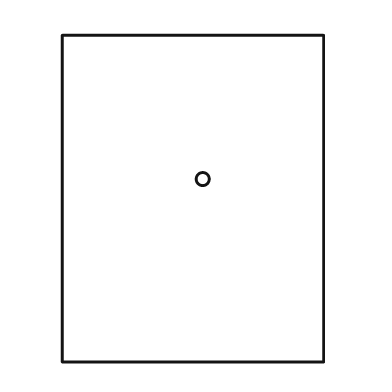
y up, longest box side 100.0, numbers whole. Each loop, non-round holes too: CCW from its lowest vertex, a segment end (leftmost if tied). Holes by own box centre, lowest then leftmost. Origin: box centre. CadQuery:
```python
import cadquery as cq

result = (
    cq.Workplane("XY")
    .moveTo(-40.0, -50.0)
    .lineTo(40.0, -50.0)
    .lineTo(40.0, 50.0)
    .lineTo(-40.0, 50.0)
    .close()
    .moveTo(3.0, 6.0)
    .circle(2.0)
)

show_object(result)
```